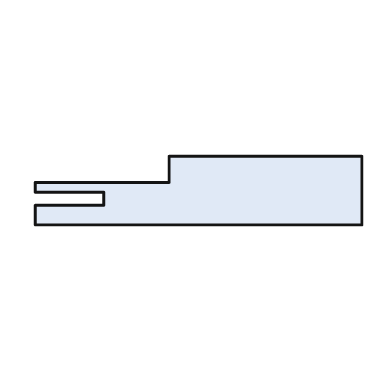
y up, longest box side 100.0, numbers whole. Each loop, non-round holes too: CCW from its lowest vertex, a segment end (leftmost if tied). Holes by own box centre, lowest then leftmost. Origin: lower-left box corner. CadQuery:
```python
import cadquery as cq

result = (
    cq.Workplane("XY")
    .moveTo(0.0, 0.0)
    .lineTo(100.0, 0.0)
    .lineTo(100.0, 21.0)
    .lineTo(41.0, 21.0)
    .lineTo(41.0, 13.0)
    .lineTo(0.0, 13.0)
    .lineTo(0.0, 10.0)
    .lineTo(21.0, 10.0)
    .lineTo(21.0, 6.0)
    .lineTo(0.0, 6.0)
    .close()
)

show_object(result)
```